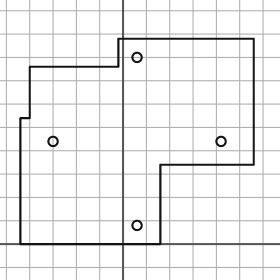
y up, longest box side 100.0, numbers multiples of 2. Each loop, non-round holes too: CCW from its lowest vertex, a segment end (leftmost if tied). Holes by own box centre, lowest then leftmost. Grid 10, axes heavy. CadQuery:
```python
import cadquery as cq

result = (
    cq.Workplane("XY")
    .moveTo(-44.0, 0.0)
    .lineTo(16.0, 0.0)
    .lineTo(16.0, 34.0)
    .lineTo(56.0, 34.0)
    .lineTo(56.0, 88.0)
    .lineTo(-2.0, 88.0)
    .lineTo(-2.0, 76.0)
    .lineTo(-40.0, 76.0)
    .lineTo(-40.0, 54.0)
    .lineTo(-44.0, 54.0)
    .close()
    .moveTo(6.0, 8.0)
    .circle(2.0)
    .moveTo(-30.0, 44.0)
    .circle(2.0)
    .moveTo(42.0, 44.0)
    .circle(2.0)
    .moveTo(6.0, 80.0)
    .circle(2.0)
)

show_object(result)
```